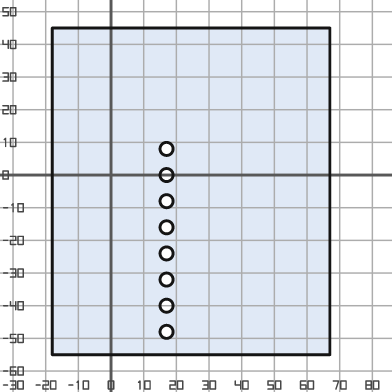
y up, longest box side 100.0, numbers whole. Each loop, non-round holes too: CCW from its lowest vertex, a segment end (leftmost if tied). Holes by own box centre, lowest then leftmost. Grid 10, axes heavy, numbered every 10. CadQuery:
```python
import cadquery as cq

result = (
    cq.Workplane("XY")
    .moveTo(-18.0, -55.0)
    .lineTo(67.0, -55.0)
    .lineTo(67.0, 45.0)
    .lineTo(-18.0, 45.0)
    .close()
    .moveTo(17.0, -48.0)
    .circle(2.0)
    .moveTo(17.0, -40.0)
    .circle(2.0)
    .moveTo(17.0, -32.0)
    .circle(2.0)
    .moveTo(17.0, -24.0)
    .circle(2.0)
    .moveTo(17.0, -16.0)
    .circle(2.0)
    .moveTo(17.0, -8.0)
    .circle(2.0)
    .moveTo(17.0, 0.0)
    .circle(2.0)
    .moveTo(17.0, 8.0)
    .circle(2.0)
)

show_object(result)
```